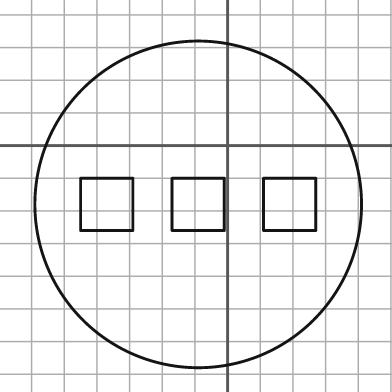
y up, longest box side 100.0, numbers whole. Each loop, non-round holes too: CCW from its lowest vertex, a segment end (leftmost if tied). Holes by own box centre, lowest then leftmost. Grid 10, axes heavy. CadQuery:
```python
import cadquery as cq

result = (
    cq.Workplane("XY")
    .moveTo(-9.0, -18.0)
    .circle(50.0)
    .moveTo(-45.0, -26.0)
    .lineTo(-29.0, -26.0)
    .lineTo(-29.0, -10.0)
    .lineTo(-45.0, -10.0)
    .close()
    .moveTo(-17.0, -26.0)
    .lineTo(-1.0, -26.0)
    .lineTo(-1.0, -10.0)
    .lineTo(-17.0, -10.0)
    .close()
    .moveTo(11.0, -26.0)
    .lineTo(27.0, -26.0)
    .lineTo(27.0, -10.0)
    .lineTo(11.0, -10.0)
    .close()
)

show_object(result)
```